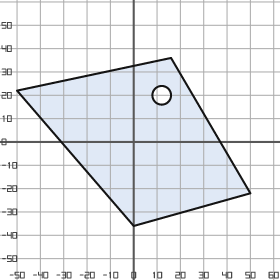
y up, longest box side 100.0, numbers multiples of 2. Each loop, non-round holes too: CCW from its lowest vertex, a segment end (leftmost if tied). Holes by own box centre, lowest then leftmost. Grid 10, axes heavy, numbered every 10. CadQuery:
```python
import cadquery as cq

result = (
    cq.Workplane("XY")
    .moveTo(0.0, -36.0)
    .lineTo(50.0, -22.0)
    .lineTo(16.0, 36.0)
    .lineTo(-50.0, 22.0)
    .close()
    .moveTo(12.0, 20.0)
    .circle(4.0)
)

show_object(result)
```